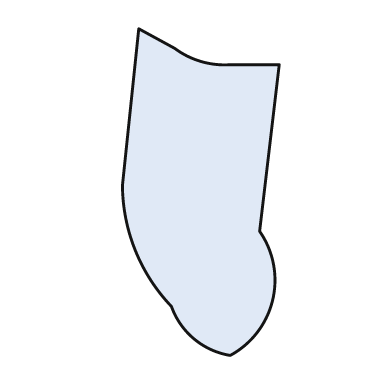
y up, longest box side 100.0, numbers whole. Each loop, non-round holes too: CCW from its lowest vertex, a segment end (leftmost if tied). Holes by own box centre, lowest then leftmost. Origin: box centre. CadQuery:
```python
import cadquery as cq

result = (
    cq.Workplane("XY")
    .moveTo(9.0, -50.0)
    .threePointArc((22.0, -33.0), (18.0, -12.0))
    .lineTo(24.0, 39.0)
    .lineTo(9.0, 39.0)
    .threePointArc((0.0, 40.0), (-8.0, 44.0))
    .lineTo(-19.0, 50.0)
    .lineTo(-24.0, 2.0)
    .threePointArc((-20.0, -18.0), (-9.0, -35.0))
    .threePointArc((-2.0, -45.0), (9.0, -50.0))
    .close()
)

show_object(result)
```